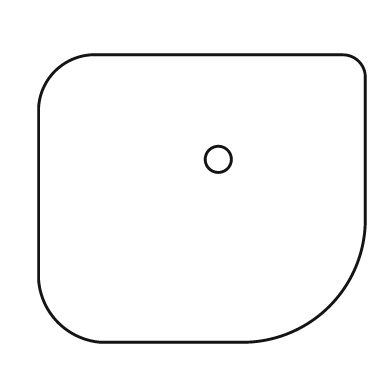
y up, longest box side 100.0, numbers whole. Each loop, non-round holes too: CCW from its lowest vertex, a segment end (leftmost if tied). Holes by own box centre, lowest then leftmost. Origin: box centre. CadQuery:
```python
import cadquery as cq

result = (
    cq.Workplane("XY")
    .moveTo(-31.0, -44.0)
    .lineTo(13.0, -44.0)
    .threePointArc((39.0, -33.0), (50.0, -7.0))
    .lineTo(50.0, 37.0)
    .threePointArc((48.0, 42.0), (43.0, 44.0))
    .lineTo(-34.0, 44.0)
    .threePointArc((-45.0, 39.0), (-50.0, 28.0))
    .lineTo(-50.0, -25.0)
    .threePointArc((-44.0, -38.0), (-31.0, -44.0))
    .close()
    .moveTo(5.0, 12.0)
    .circle(4.0)
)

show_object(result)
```